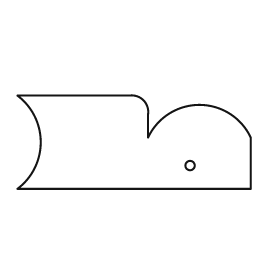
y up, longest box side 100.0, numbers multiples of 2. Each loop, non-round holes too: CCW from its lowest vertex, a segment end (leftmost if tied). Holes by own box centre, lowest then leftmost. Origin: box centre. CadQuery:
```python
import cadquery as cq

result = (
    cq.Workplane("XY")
    .moveTo(-50.0, -20.0)
    .lineTo(50.0, -20.0)
    .lineTo(50.0, 2.0)
    .threePointArc((28.0, 16.0), (6.0, 2.0))
    .lineTo(6.0, 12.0)
    .threePointArc((4.0, 18.0), (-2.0, 20.0))
    .lineTo(-50.0, 20.0)
    .threePointArc((-40.0, 0.0), (-50.0, -20.0))
    .close()
    .moveTo(24.0, -10.0)
    .circle(2.0)
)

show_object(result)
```